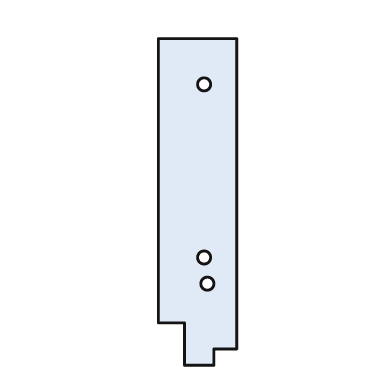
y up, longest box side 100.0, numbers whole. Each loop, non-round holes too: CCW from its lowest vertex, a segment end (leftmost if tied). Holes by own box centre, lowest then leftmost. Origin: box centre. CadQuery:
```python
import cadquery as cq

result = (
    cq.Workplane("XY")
    .moveTo(-4.0, -50.0)
    .lineTo(5.0, -50.0)
    .lineTo(5.0, -45.0)
    .lineTo(12.0, -45.0)
    .lineTo(12.0, 50.0)
    .lineTo(-12.0, 50.0)
    .lineTo(-12.0, -37.0)
    .lineTo(-4.0, -37.0)
    .close()
    .moveTo(3.0, -25.0)
    .circle(2.0)
    .moveTo(2.0, -17.0)
    .circle(2.0)
    .moveTo(2.0, 36.0)
    .circle(2.0)
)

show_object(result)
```